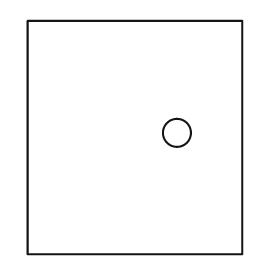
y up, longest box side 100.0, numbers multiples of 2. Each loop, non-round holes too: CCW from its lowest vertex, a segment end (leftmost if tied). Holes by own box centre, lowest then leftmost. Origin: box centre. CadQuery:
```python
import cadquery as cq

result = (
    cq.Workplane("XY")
    .moveTo(-46.0, -50.0)
    .lineTo(46.0, -50.0)
    .lineTo(46.0, 50.0)
    .lineTo(-46.0, 50.0)
    .close()
    .moveTo(18.0, 2.0)
    .circle(6.0)
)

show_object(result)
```